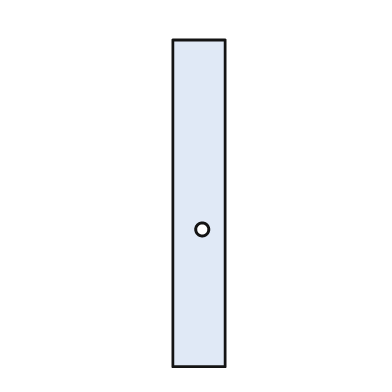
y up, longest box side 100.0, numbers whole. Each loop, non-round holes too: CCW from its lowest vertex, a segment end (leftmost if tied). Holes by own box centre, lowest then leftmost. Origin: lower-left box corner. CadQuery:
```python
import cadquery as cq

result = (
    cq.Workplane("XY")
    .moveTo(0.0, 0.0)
    .lineTo(16.0, 0.0)
    .lineTo(16.0, 100.0)
    .lineTo(0.0, 100.0)
    .close()
    .moveTo(9.0, 42.0)
    .circle(2.0)
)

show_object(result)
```